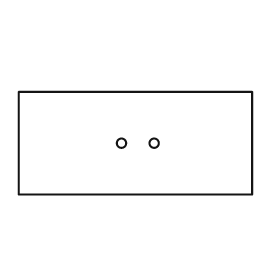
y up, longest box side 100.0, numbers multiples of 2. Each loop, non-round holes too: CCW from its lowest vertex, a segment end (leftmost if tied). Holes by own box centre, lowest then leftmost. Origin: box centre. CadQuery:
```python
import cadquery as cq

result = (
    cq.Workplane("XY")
    .moveTo(-50.0, -22.0)
    .lineTo(50.0, -22.0)
    .lineTo(50.0, 22.0)
    .lineTo(-50.0, 22.0)
    .close()
    .moveTo(-6.0, 0.0)
    .circle(2.0)
    .moveTo(8.0, 0.0)
    .circle(2.0)
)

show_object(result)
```